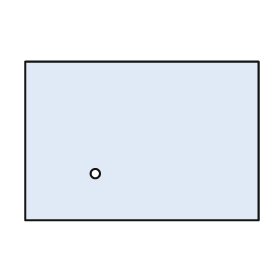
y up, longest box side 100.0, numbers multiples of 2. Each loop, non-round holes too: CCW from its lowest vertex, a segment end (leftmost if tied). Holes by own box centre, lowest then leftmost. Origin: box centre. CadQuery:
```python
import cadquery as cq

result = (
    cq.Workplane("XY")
    .moveTo(-50.0, -34.0)
    .lineTo(50.0, -34.0)
    .lineTo(50.0, 34.0)
    .lineTo(-50.0, 34.0)
    .close()
    .moveTo(-20.0, -14.0)
    .circle(2.0)
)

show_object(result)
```